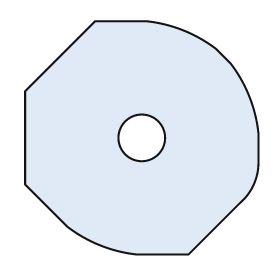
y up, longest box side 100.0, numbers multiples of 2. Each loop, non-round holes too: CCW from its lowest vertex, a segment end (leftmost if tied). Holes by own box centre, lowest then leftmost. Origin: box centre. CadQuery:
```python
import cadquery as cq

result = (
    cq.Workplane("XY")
    .moveTo(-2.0, -50.0)
    .lineTo(20.0, -50.0)
    .lineTo(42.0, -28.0)
    .threePointArc((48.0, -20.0), (50.0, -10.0))
    .lineTo(50.0, 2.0)
    .threePointArc((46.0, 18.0), (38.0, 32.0))
    .lineTo(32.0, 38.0)
    .threePointArc((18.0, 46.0), (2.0, 50.0))
    .lineTo(-20.0, 50.0)
    .lineTo(-50.0, 20.0)
    .lineTo(-50.0, -20.0)
    .lineTo(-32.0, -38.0)
    .threePointArc((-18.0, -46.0), (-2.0, -50.0))
    .close()
    .moveTo(0.0, 0.0)
    .circle(10.0)
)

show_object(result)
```